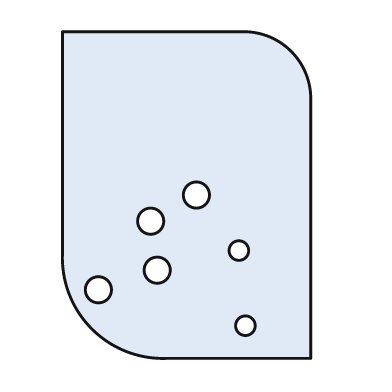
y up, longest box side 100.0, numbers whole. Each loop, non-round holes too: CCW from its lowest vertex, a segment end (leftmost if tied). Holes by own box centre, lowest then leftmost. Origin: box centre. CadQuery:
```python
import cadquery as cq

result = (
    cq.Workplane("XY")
    .moveTo(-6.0, -50.0)
    .lineTo(38.0, -50.0)
    .lineTo(38.0, 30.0)
    .threePointArc((32.0, 44.0), (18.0, 50.0))
    .lineTo(-38.0, 50.0)
    .lineTo(-38.0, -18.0)
    .threePointArc((-29.0, -41.0), (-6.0, -50.0))
    .close()
    .moveTo(18.0, -40.0)
    .circle(3.0)
    .moveTo(-27.0, -29.0)
    .circle(4.0)
    .moveTo(-9.0, -23.0)
    .circle(4.0)
    .moveTo(16.0, -17.0)
    .circle(3.0)
    .moveTo(-11.0, -8.0)
    .circle(4.0)
    .moveTo(3.0, 0.0)
    .circle(4.0)
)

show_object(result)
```